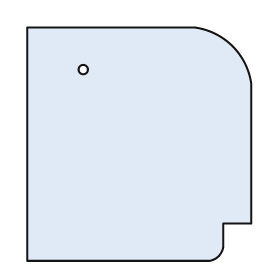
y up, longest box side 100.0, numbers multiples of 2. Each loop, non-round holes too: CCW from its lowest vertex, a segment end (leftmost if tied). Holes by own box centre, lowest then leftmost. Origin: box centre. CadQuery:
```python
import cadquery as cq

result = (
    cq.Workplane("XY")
    .moveTo(-48.0, -50.0)
    .lineTo(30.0, -50.0)
    .threePointArc((34.0, -48.0), (36.0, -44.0))
    .lineTo(36.0, -34.0)
    .lineTo(48.0, -34.0)
    .lineTo(48.0, 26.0)
    .threePointArc((40.0, 42.0), (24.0, 50.0))
    .lineTo(-48.0, 50.0)
    .close()
    .moveTo(-24.0, 32.0)
    .circle(2.0)
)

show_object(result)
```